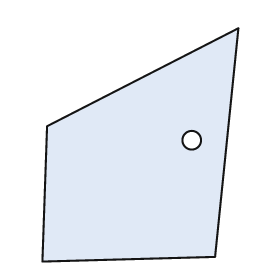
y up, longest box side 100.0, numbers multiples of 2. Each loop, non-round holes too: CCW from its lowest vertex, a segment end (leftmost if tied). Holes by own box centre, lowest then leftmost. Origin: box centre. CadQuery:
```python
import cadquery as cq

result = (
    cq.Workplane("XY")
    .moveTo(-42.0, -50.0)
    .lineTo(32.0, -48.0)
    .lineTo(42.0, 50.0)
    .lineTo(-40.0, 8.0)
    .close()
    .moveTo(22.0, 2.0)
    .circle(4.0)
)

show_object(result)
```